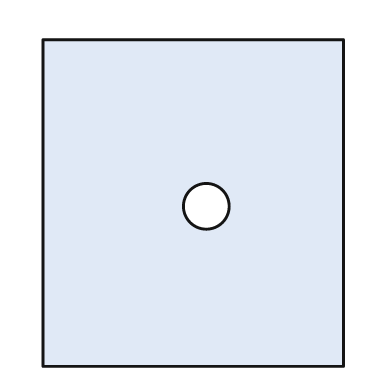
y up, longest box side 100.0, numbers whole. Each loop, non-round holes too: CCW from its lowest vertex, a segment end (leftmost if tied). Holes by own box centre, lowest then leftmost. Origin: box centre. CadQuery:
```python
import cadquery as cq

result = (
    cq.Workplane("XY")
    .moveTo(-46.0, -50.0)
    .lineTo(46.0, -50.0)
    .lineTo(46.0, 50.0)
    .lineTo(-46.0, 50.0)
    .close()
    .moveTo(4.0, -1.0)
    .circle(7.0)
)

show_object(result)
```